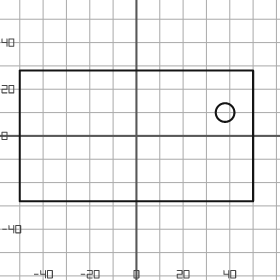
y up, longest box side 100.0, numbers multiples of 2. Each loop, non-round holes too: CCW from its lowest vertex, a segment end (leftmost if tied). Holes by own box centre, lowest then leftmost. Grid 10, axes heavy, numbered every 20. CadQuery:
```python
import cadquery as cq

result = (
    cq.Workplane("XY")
    .moveTo(-50.0, -28.0)
    .lineTo(50.0, -28.0)
    .lineTo(50.0, 28.0)
    .lineTo(-50.0, 28.0)
    .close()
    .moveTo(38.0, 10.0)
    .circle(4.0)
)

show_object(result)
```